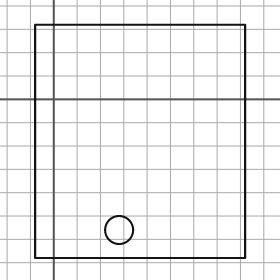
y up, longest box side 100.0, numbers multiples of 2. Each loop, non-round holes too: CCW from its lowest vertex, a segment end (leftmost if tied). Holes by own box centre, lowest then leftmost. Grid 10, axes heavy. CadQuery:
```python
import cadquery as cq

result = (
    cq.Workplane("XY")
    .moveTo(-8.0, -68.0)
    .lineTo(82.0, -68.0)
    .lineTo(82.0, 32.0)
    .lineTo(-8.0, 32.0)
    .close()
    .moveTo(28.0, -56.0)
    .circle(6.0)
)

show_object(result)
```